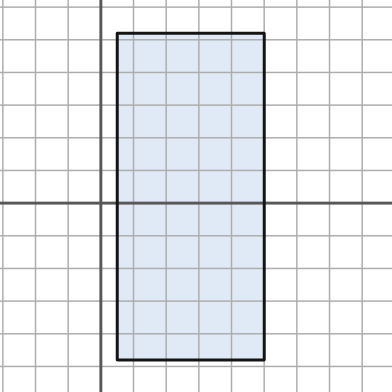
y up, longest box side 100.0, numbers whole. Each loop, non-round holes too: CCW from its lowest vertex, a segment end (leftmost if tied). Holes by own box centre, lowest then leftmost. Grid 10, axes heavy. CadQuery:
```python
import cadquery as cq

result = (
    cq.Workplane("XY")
    .moveTo(5.0, -48.0)
    .lineTo(50.0, -48.0)
    .lineTo(50.0, 52.0)
    .lineTo(5.0, 52.0)
    .close()
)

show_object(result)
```